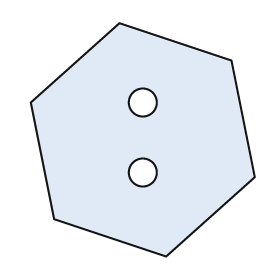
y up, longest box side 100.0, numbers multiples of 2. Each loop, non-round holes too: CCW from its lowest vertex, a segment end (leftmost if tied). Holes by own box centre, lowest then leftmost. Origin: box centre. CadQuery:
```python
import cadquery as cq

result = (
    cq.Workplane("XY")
    .moveTo(10.0, -50.0)
    .lineTo(48.0, -16.0)
    .lineTo(38.0, 34.0)
    .lineTo(-10.0, 50.0)
    .lineTo(-48.0, 16.0)
    .lineTo(-38.0, -34.0)
    .close()
    .moveTo(0.0, -14.0)
    .circle(6.0)
    .moveTo(0.0, 16.0)
    .circle(6.0)
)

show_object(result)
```